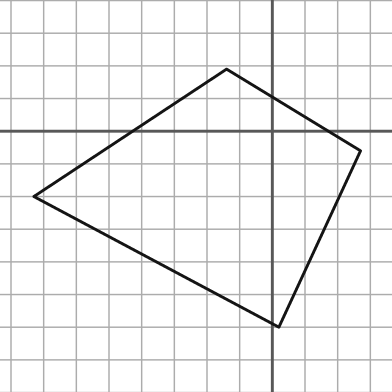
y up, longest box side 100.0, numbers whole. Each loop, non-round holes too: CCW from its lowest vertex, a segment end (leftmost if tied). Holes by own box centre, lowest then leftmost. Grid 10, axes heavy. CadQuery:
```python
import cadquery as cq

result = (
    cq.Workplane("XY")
    .moveTo(2.0, -60.0)
    .lineTo(27.0, -6.0)
    .lineTo(-14.0, 19.0)
    .lineTo(-73.0, -20.0)
    .close()
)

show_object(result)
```